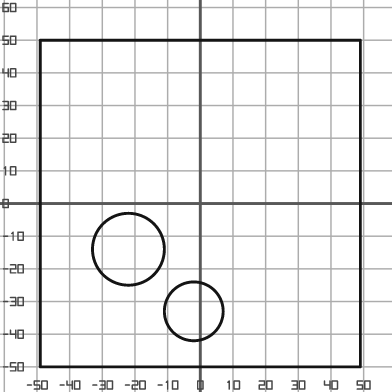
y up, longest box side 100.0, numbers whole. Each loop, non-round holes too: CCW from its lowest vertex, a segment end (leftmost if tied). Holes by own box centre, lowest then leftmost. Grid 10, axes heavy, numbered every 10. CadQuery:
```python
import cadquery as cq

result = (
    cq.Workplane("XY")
    .moveTo(-49.0, -50.0)
    .lineTo(49.0, -50.0)
    .lineTo(49.0, 50.0)
    .lineTo(-49.0, 50.0)
    .close()
    .moveTo(-2.0, -33.0)
    .circle(9.0)
    .moveTo(-22.0, -14.0)
    .circle(11.0)
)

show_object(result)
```